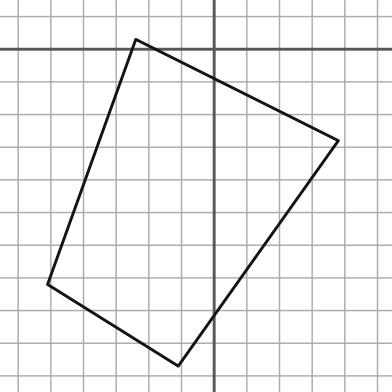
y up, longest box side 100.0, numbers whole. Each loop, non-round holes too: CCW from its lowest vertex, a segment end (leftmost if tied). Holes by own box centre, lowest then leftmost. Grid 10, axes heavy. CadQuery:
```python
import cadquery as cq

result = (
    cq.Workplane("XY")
    .moveTo(-11.0, -97.0)
    .lineTo(38.0, -28.0)
    .lineTo(-24.0, 3.0)
    .lineTo(-51.0, -72.0)
    .close()
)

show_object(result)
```